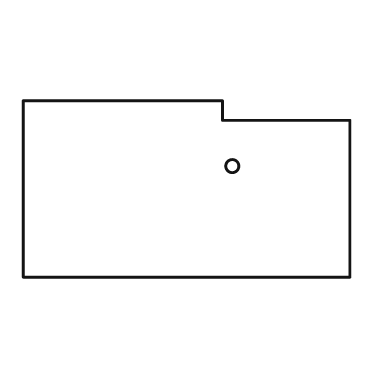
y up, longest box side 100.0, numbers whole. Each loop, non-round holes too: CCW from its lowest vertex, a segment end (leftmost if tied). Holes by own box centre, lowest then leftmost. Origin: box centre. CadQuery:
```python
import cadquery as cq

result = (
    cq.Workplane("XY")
    .moveTo(-50.0, -27.0)
    .lineTo(50.0, -27.0)
    .lineTo(50.0, 21.0)
    .lineTo(11.0, 21.0)
    .lineTo(11.0, 27.0)
    .lineTo(-50.0, 27.0)
    .close()
    .moveTo(14.0, 7.0)
    .circle(2.0)
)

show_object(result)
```